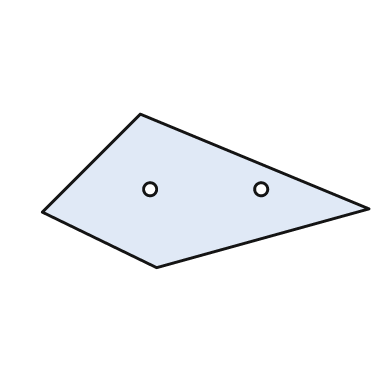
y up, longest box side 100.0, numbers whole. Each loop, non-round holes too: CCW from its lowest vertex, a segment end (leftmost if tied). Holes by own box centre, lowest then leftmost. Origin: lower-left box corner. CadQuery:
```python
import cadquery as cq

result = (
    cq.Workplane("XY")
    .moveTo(35.0, 0.0)
    .lineTo(100.0, 18.0)
    .lineTo(30.0, 47.0)
    .lineTo(0.0, 17.0)
    .close()
    .moveTo(33.0, 24.0)
    .circle(2.0)
    .moveTo(67.0, 24.0)
    .circle(2.0)
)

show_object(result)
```